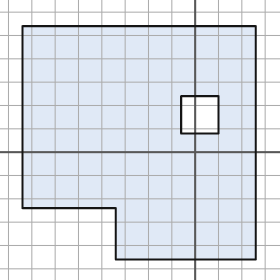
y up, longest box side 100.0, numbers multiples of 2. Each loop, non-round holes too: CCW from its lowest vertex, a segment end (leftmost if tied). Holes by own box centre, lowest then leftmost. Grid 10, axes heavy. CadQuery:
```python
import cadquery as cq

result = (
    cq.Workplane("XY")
    .moveTo(-34.0, -46.0)
    .lineTo(26.0, -46.0)
    .lineTo(26.0, 54.0)
    .lineTo(-74.0, 54.0)
    .lineTo(-74.0, -24.0)
    .lineTo(-34.0, -24.0)
    .close()
    .moveTo(-6.0, 8.0)
    .lineTo(10.0, 8.0)
    .lineTo(10.0, 24.0)
    .lineTo(-6.0, 24.0)
    .close()
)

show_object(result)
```